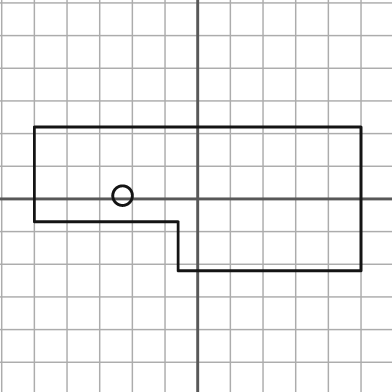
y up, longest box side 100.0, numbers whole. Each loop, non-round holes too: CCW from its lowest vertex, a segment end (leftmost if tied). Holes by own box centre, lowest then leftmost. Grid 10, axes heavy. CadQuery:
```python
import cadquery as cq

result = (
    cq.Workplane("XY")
    .moveTo(-6.0, -22.0)
    .lineTo(50.0, -22.0)
    .lineTo(50.0, 22.0)
    .lineTo(-50.0, 22.0)
    .lineTo(-50.0, -7.0)
    .lineTo(-6.0, -7.0)
    .close()
    .moveTo(-23.0, 1.0)
    .circle(3.0)
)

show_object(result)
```